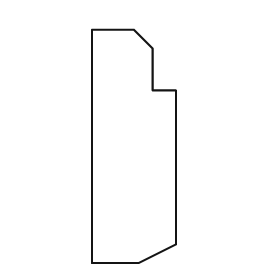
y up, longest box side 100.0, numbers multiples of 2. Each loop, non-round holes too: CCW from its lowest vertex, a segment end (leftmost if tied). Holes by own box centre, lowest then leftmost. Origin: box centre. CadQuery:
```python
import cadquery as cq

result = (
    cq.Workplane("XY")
    .moveTo(-18.0, -50.0)
    .lineTo(2.0, -50.0)
    .lineTo(18.0, -42.0)
    .lineTo(18.0, 24.0)
    .lineTo(8.0, 24.0)
    .lineTo(8.0, 42.0)
    .lineTo(0.0, 50.0)
    .lineTo(-18.0, 50.0)
    .close()
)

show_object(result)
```